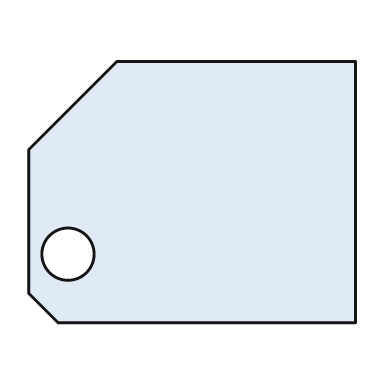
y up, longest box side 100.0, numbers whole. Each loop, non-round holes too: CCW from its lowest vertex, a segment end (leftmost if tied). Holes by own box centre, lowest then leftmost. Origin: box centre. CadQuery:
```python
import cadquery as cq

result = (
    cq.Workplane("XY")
    .moveTo(-41.0, -40.0)
    .lineTo(50.0, -40.0)
    .lineTo(50.0, 40.0)
    .lineTo(-23.0, 40.0)
    .lineTo(-50.0, 13.0)
    .lineTo(-50.0, -31.0)
    .close()
    .moveTo(-38.0, -19.0)
    .circle(8.0)
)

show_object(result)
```